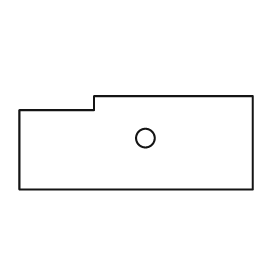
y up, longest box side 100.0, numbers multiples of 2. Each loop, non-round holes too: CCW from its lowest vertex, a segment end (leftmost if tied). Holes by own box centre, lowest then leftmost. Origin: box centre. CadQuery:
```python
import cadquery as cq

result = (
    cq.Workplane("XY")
    .moveTo(-50.0, -20.0)
    .lineTo(50.0, -20.0)
    .lineTo(50.0, 20.0)
    .lineTo(-18.0, 20.0)
    .lineTo(-18.0, 14.0)
    .lineTo(-50.0, 14.0)
    .close()
    .moveTo(4.0, 2.0)
    .circle(4.0)
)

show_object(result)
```